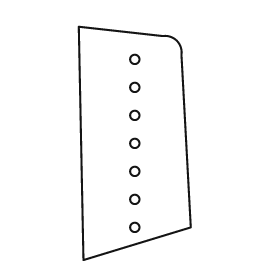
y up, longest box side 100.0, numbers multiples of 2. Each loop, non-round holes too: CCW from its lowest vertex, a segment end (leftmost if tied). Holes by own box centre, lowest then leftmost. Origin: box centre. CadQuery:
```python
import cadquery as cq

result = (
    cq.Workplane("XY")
    .moveTo(-22.0, -50.0)
    .lineTo(24.0, -36.0)
    .lineTo(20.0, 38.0)
    .threePointArc((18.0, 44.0), (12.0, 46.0))
    .lineTo(-24.0, 50.0)
    .close()
    .moveTo(0.0, -36.0)
    .circle(2.0)
    .moveTo(0.0, -24.0)
    .circle(2.0)
    .moveTo(0.0, -12.0)
    .circle(2.0)
    .moveTo(0.0, 0.0)
    .circle(2.0)
    .moveTo(0.0, 12.0)
    .circle(2.0)
    .moveTo(0.0, 24.0)
    .circle(2.0)
    .moveTo(0.0, 36.0)
    .circle(2.0)
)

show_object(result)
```